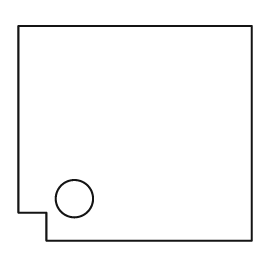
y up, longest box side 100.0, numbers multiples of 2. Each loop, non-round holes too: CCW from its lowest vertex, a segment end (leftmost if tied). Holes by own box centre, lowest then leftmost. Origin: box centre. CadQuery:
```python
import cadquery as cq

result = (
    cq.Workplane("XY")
    .moveTo(-38.0, -46.0)
    .lineTo(50.0, -46.0)
    .lineTo(50.0, 46.0)
    .lineTo(-50.0, 46.0)
    .lineTo(-50.0, -34.0)
    .lineTo(-38.0, -34.0)
    .close()
    .moveTo(-26.0, -28.0)
    .circle(8.0)
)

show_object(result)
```